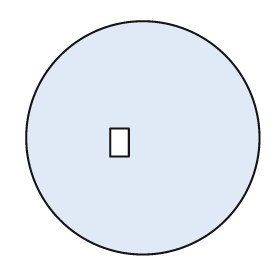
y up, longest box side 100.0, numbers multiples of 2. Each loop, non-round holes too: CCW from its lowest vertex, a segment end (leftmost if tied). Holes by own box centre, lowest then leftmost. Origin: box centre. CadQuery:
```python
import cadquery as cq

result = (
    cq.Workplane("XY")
    .moveTo(0.0, 0.0)
    .circle(50.0)
    .moveTo(-14.0, -8.0)
    .lineTo(-6.0, -8.0)
    .lineTo(-6.0, 4.0)
    .lineTo(-14.0, 4.0)
    .close()
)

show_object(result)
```